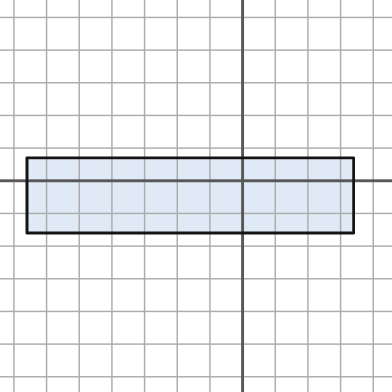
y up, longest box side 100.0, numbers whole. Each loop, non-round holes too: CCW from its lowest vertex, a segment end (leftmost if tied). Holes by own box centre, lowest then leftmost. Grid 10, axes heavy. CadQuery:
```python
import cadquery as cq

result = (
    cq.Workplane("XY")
    .moveTo(-66.0, -16.0)
    .lineTo(34.0, -16.0)
    .lineTo(34.0, 7.0)
    .lineTo(-66.0, 7.0)
    .close()
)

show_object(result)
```